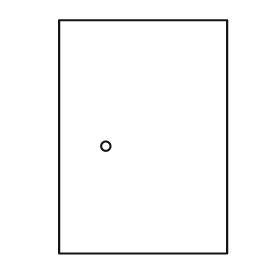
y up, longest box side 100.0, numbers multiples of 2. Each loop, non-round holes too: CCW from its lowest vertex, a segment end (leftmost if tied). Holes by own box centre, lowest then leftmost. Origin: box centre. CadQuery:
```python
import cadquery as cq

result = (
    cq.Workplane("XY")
    .moveTo(-36.0, -50.0)
    .lineTo(36.0, -50.0)
    .lineTo(36.0, 50.0)
    .lineTo(-36.0, 50.0)
    .close()
    .moveTo(-16.0, -4.0)
    .circle(2.0)
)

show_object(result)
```